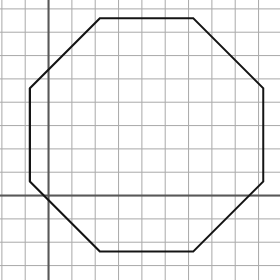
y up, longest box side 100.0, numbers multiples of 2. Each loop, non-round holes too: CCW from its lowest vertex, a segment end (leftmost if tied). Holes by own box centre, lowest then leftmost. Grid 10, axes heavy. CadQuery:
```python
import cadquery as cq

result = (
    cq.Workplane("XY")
    .moveTo(22.0, -24.0)
    .lineTo(62.0, -24.0)
    .lineTo(92.0, 6.0)
    .lineTo(92.0, 46.0)
    .lineTo(62.0, 76.0)
    .lineTo(22.0, 76.0)
    .lineTo(-8.0, 46.0)
    .lineTo(-8.0, 6.0)
    .close()
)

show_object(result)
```